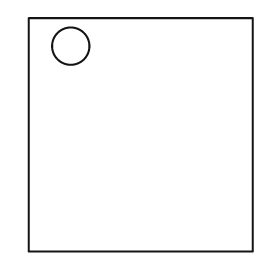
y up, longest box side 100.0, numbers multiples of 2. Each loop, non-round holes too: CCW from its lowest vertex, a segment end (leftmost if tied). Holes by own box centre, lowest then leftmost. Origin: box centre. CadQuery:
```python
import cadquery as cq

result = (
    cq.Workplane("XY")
    .moveTo(-48.0, -50.0)
    .lineTo(48.0, -50.0)
    .lineTo(48.0, 50.0)
    .lineTo(-48.0, 50.0)
    .close()
    .moveTo(-30.0, 38.0)
    .circle(8.0)
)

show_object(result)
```